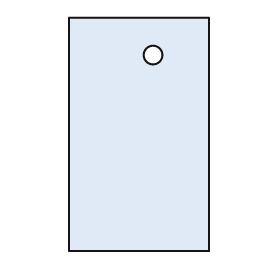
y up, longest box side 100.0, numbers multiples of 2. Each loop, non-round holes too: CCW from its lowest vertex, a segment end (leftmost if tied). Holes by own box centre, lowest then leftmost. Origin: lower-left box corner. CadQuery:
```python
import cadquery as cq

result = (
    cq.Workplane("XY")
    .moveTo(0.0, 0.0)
    .lineTo(60.0, 0.0)
    .lineTo(60.0, 100.0)
    .lineTo(0.0, 100.0)
    .close()
    .moveTo(36.0, 84.0)
    .circle(4.0)
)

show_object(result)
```